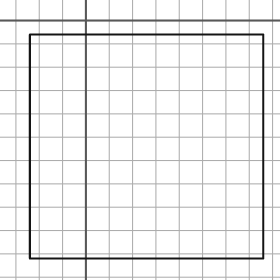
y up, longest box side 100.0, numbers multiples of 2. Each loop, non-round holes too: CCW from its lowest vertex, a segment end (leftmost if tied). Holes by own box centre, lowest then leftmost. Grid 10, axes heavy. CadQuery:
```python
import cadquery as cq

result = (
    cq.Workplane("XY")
    .moveTo(-24.0, -102.0)
    .lineTo(76.0, -102.0)
    .lineTo(76.0, -6.0)
    .lineTo(-24.0, -6.0)
    .close()
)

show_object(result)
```